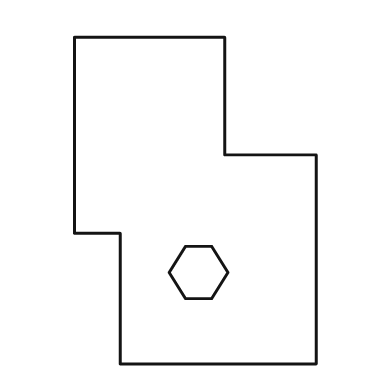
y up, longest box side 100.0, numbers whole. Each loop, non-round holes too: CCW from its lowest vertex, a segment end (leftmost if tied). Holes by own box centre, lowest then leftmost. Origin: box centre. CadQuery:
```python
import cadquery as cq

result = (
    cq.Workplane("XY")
    .moveTo(-23.0, -50.0)
    .lineTo(37.0, -50.0)
    .lineTo(37.0, 14.0)
    .lineTo(9.0, 14.0)
    .lineTo(9.0, 50.0)
    .lineTo(-37.0, 50.0)
    .lineTo(-37.0, -10.0)
    .lineTo(-23.0, -10.0)
    .close()
    .moveTo(-3.0, -30.0)
    .lineTo(5.0, -30.0)
    .lineTo(10.0, -22.0)
    .lineTo(5.0, -14.0)
    .lineTo(-3.0, -14.0)
    .lineTo(-8.0, -22.0)
    .close()
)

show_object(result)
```